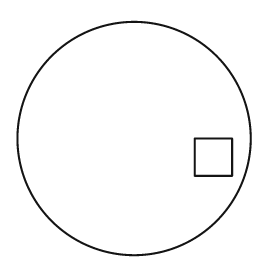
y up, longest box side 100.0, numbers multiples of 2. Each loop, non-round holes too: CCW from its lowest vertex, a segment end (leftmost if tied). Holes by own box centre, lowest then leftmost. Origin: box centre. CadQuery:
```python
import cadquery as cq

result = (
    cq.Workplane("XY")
    .moveTo(0.0, 0.0)
    .circle(50.0)
    .moveTo(26.0, -16.0)
    .lineTo(42.0, -16.0)
    .lineTo(42.0, 0.0)
    .lineTo(26.0, 0.0)
    .close()
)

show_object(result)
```